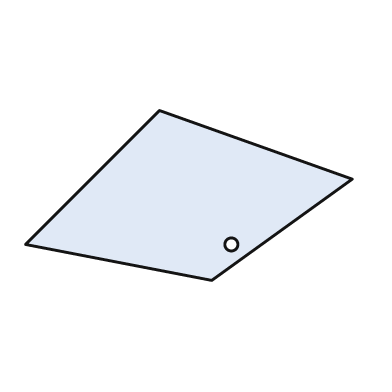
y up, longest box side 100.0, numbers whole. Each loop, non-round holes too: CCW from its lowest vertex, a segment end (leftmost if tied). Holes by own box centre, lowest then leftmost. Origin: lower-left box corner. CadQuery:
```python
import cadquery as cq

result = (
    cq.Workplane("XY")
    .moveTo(57.0, 0.0)
    .lineTo(100.0, 31.0)
    .lineTo(41.0, 52.0)
    .lineTo(0.0, 11.0)
    .close()
    .moveTo(63.0, 11.0)
    .circle(2.0)
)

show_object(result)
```